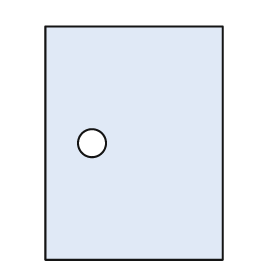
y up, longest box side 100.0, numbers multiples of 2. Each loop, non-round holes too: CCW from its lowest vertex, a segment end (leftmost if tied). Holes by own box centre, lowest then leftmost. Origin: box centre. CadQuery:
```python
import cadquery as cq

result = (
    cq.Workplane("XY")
    .moveTo(-38.0, -50.0)
    .lineTo(38.0, -50.0)
    .lineTo(38.0, 50.0)
    .lineTo(-38.0, 50.0)
    .close()
    .moveTo(-18.0, 0.0)
    .circle(6.0)
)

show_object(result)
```